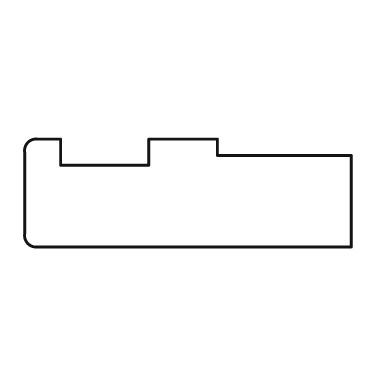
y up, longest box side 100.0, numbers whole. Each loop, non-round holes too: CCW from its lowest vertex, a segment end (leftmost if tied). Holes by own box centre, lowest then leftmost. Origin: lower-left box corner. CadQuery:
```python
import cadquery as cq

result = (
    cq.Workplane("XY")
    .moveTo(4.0, 0.0)
    .lineTo(100.0, 0.0)
    .lineTo(100.0, 28.0)
    .lineTo(59.0, 28.0)
    .lineTo(59.0, 33.0)
    .lineTo(38.0, 33.0)
    .lineTo(38.0, 25.0)
    .lineTo(11.0, 25.0)
    .lineTo(11.0, 33.0)
    .lineTo(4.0, 33.0)
    .threePointArc((1.0, 32.0), (0.0, 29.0))
    .lineTo(0.0, 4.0)
    .threePointArc((1.0, 1.0), (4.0, 0.0))
    .close()
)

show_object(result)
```